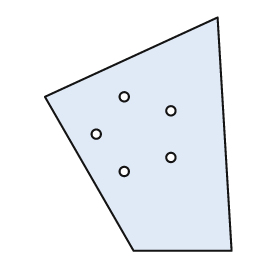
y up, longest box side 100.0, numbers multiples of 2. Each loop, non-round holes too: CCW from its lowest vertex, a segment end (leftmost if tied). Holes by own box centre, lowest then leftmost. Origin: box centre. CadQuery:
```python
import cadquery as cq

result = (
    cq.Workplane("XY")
    .moveTo(-2.0, -50.0)
    .lineTo(40.0, -50.0)
    .lineTo(34.0, 50.0)
    .lineTo(-40.0, 16.0)
    .close()
    .moveTo(-6.0, -16.0)
    .circle(2.0)
    .moveTo(14.0, -10.0)
    .circle(2.0)
    .moveTo(-18.0, 0.0)
    .circle(2.0)
    .moveTo(14.0, 10.0)
    .circle(2.0)
    .moveTo(-6.0, 16.0)
    .circle(2.0)
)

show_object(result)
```